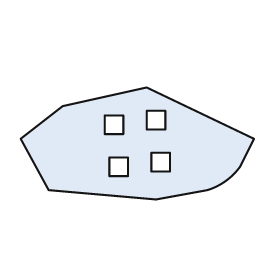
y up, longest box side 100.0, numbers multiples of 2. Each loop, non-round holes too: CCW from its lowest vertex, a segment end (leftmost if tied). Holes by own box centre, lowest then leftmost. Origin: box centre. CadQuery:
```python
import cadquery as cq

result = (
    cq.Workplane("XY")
    .moveTo(8.0, -24.0)
    .lineTo(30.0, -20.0)
    .threePointArc((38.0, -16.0), (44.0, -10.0))
    .lineTo(50.0, 2.0)
    .lineTo(4.0, 24.0)
    .lineTo(-32.0, 16.0)
    .lineTo(-50.0, 2.0)
    .lineTo(-38.0, -20.0)
    .close()
    .moveTo(-12.0, -14.0)
    .lineTo(-4.0, -14.0)
    .lineTo(-4.0, -6.0)
    .lineTo(-12.0, -6.0)
    .close()
    .moveTo(6.0, -12.0)
    .lineTo(14.0, -12.0)
    .lineTo(14.0, -4.0)
    .lineTo(6.0, -4.0)
    .close()
    .moveTo(-14.0, 4.0)
    .lineTo(-6.0, 4.0)
    .lineTo(-6.0, 12.0)
    .lineTo(-14.0, 12.0)
    .close()
    .moveTo(4.0, 6.0)
    .lineTo(12.0, 6.0)
    .lineTo(12.0, 14.0)
    .lineTo(4.0, 14.0)
    .close()
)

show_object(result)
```